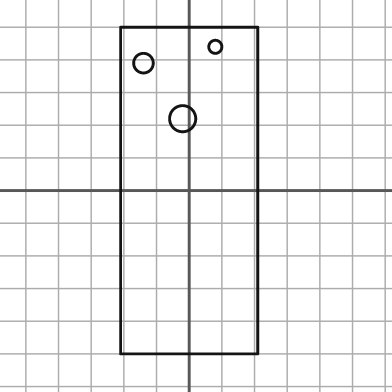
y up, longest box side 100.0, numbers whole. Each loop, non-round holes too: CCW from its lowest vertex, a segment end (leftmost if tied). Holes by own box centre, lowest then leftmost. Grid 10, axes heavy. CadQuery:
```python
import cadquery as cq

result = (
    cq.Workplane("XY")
    .moveTo(-21.0, -50.0)
    .lineTo(21.0, -50.0)
    .lineTo(21.0, 50.0)
    .lineTo(-21.0, 50.0)
    .close()
    .moveTo(-2.0, 22.0)
    .circle(4.0)
    .moveTo(-14.0, 39.0)
    .circle(3.0)
    .moveTo(8.0, 44.0)
    .circle(2.0)
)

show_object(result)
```